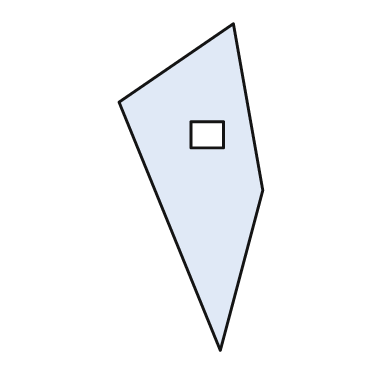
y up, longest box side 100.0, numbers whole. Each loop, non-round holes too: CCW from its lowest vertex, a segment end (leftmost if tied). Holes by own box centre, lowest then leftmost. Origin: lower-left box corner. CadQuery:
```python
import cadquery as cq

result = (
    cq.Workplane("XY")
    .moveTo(31.0, 0.0)
    .lineTo(44.0, 49.0)
    .lineTo(35.0, 100.0)
    .lineTo(0.0, 76.0)
    .close()
    .moveTo(22.0, 62.0)
    .lineTo(32.0, 62.0)
    .lineTo(32.0, 70.0)
    .lineTo(22.0, 70.0)
    .close()
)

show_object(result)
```